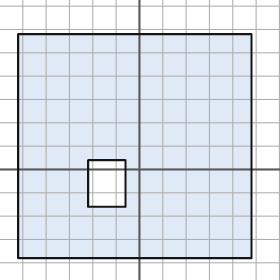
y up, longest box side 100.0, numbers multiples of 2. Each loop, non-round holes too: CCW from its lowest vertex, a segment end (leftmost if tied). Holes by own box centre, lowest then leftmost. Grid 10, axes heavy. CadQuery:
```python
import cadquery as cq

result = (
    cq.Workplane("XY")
    .moveTo(-52.0, -38.0)
    .lineTo(48.0, -38.0)
    .lineTo(48.0, 58.0)
    .lineTo(-52.0, 58.0)
    .close()
    .moveTo(-22.0, -16.0)
    .lineTo(-6.0, -16.0)
    .lineTo(-6.0, 4.0)
    .lineTo(-22.0, 4.0)
    .close()
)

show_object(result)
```